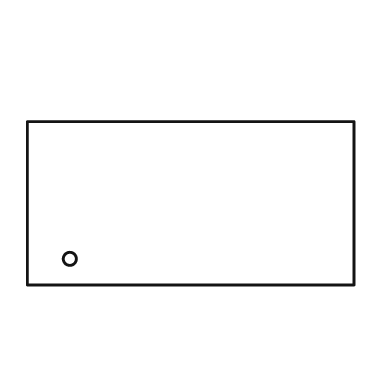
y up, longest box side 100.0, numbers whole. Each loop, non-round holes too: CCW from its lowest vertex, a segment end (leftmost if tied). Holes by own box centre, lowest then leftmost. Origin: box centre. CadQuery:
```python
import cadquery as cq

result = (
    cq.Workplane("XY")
    .moveTo(-50.0, -25.0)
    .lineTo(50.0, -25.0)
    .lineTo(50.0, 25.0)
    .lineTo(-50.0, 25.0)
    .close()
    .moveTo(-37.0, -17.0)
    .circle(2.0)
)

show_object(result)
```